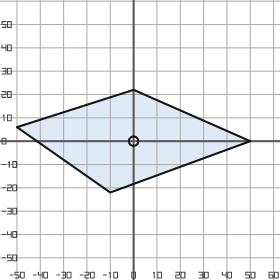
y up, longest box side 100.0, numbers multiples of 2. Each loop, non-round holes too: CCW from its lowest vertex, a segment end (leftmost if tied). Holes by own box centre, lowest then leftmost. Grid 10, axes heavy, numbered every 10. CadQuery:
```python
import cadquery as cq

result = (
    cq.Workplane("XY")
    .moveTo(-10.0, -22.0)
    .lineTo(50.0, 0.0)
    .lineTo(0.0, 22.0)
    .lineTo(-50.0, 6.0)
    .close()
    .moveTo(0.0, 0.0)
    .circle(2.0)
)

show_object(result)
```